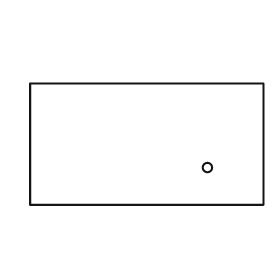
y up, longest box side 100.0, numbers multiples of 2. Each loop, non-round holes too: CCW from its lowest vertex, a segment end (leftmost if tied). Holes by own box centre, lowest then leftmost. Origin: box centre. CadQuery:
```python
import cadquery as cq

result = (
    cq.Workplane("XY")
    .moveTo(-50.0, -26.0)
    .lineTo(50.0, -26.0)
    .lineTo(50.0, 26.0)
    .lineTo(-50.0, 26.0)
    .close()
    .moveTo(26.0, -10.0)
    .circle(2.0)
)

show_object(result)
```